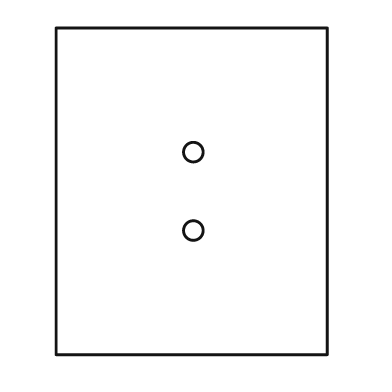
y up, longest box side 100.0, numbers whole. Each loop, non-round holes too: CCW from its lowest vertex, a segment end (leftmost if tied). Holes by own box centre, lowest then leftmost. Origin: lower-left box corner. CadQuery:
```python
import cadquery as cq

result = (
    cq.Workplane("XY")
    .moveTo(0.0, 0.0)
    .lineTo(83.0, 0.0)
    .lineTo(83.0, 100.0)
    .lineTo(0.0, 100.0)
    .close()
    .moveTo(42.0, 38.0)
    .circle(3.0)
    .moveTo(42.0, 62.0)
    .circle(3.0)
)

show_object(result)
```